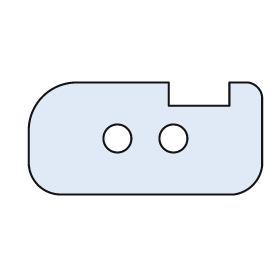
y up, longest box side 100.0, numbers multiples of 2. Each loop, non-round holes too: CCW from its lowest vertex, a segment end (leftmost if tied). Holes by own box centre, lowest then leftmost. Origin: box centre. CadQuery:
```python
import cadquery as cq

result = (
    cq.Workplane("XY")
    .moveTo(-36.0, -24.0)
    .lineTo(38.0, -24.0)
    .threePointArc((46.0, -20.0), (50.0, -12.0))
    .lineTo(50.0, 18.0)
    .threePointArc((48.0, 22.0), (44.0, 24.0))
    .lineTo(36.0, 24.0)
    .lineTo(36.0, 14.0)
    .lineTo(10.0, 14.0)
    .lineTo(10.0, 24.0)
    .lineTo(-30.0, 24.0)
    .threePointArc((-44.0, 18.0), (-50.0, 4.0))
    .lineTo(-50.0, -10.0)
    .threePointArc((-46.0, -20.0), (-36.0, -24.0))
    .close()
    .moveTo(-12.0, 0.0)
    .circle(6.0)
    .moveTo(12.0, 0.0)
    .circle(6.0)
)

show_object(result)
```